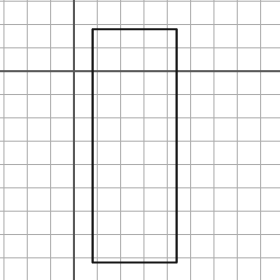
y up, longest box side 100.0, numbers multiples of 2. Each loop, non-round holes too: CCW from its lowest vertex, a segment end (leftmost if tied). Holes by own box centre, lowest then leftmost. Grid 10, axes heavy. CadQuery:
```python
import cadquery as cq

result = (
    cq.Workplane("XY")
    .moveTo(8.0, -82.0)
    .lineTo(44.0, -82.0)
    .lineTo(44.0, 18.0)
    .lineTo(8.0, 18.0)
    .close()
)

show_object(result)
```